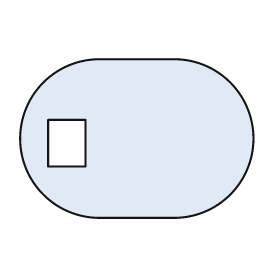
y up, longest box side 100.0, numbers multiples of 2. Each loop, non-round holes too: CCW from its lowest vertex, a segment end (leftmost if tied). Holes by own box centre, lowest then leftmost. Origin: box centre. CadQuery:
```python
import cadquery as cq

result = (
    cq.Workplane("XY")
    .moveTo(-16.0, -34.0)
    .lineTo(16.0, -34.0)
    .threePointArc((50.0, 0.0), (16.0, 34.0))
    .lineTo(-16.0, 34.0)
    .threePointArc((-50.0, 0.0), (-16.0, -34.0))
    .close()
    .moveTo(-38.0, -12.0)
    .lineTo(-22.0, -12.0)
    .lineTo(-22.0, 8.0)
    .lineTo(-38.0, 8.0)
    .close()
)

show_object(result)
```